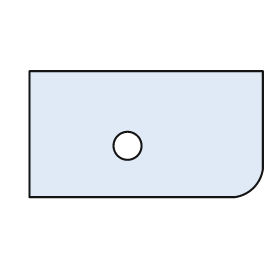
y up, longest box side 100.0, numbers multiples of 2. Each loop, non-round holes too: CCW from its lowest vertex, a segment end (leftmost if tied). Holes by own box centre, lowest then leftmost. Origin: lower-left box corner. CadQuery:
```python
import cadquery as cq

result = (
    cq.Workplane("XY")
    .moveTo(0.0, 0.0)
    .lineTo(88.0, 0.0)
    .threePointArc((96.0, 4.0), (100.0, 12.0))
    .lineTo(100.0, 54.0)
    .lineTo(0.0, 54.0)
    .close()
    .moveTo(42.0, 22.0)
    .circle(6.0)
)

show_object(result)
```